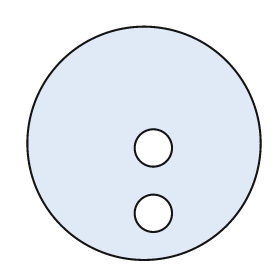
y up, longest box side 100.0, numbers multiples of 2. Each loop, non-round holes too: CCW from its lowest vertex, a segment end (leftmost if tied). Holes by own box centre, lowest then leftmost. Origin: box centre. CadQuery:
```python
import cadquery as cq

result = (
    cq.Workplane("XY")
    .moveTo(0.0, 0.0)
    .circle(50.0)
    .moveTo(4.0, -30.0)
    .circle(8.0)
    .moveTo(4.0, -2.0)
    .circle(8.0)
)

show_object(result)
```